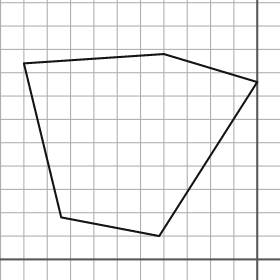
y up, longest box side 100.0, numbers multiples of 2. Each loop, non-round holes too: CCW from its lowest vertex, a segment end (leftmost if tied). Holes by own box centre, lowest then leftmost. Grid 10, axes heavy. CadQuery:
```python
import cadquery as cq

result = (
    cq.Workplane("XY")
    .moveTo(-42.0, 10.0)
    .lineTo(0.0, 76.0)
    .lineTo(-40.0, 88.0)
    .lineTo(-100.0, 84.0)
    .lineTo(-84.0, 18.0)
    .close()
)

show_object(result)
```